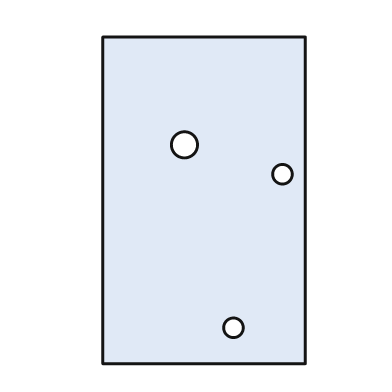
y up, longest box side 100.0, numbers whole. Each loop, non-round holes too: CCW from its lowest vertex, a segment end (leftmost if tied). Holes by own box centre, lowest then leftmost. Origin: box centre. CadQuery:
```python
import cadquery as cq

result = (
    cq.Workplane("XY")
    .moveTo(-31.0, -50.0)
    .lineTo(31.0, -50.0)
    .lineTo(31.0, 50.0)
    .lineTo(-31.0, 50.0)
    .close()
    .moveTo(9.0, -39.0)
    .circle(3.0)
    .moveTo(24.0, 8.0)
    .circle(3.0)
    .moveTo(-6.0, 17.0)
    .circle(4.0)
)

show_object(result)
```